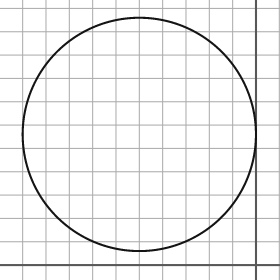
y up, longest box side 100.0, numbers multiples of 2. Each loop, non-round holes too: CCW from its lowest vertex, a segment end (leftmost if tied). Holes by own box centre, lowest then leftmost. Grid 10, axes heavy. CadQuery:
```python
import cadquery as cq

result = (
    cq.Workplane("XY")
    .moveTo(-50.0, 56.0)
    .circle(50.0)
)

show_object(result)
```